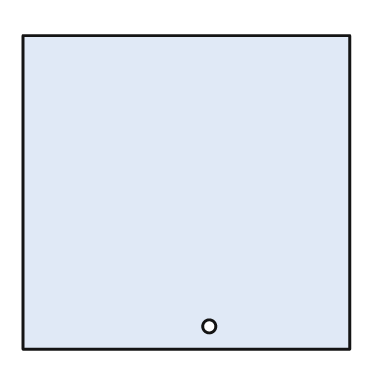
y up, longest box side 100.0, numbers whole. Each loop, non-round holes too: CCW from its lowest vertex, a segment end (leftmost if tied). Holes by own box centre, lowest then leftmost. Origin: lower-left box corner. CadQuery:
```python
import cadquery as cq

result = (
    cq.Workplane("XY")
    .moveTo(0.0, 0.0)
    .lineTo(100.0, 0.0)
    .lineTo(100.0, 96.0)
    .lineTo(0.0, 96.0)
    .close()
    .moveTo(57.0, 7.0)
    .circle(2.0)
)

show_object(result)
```